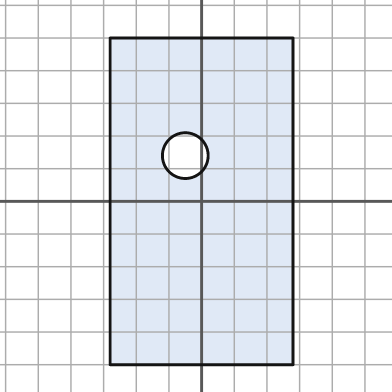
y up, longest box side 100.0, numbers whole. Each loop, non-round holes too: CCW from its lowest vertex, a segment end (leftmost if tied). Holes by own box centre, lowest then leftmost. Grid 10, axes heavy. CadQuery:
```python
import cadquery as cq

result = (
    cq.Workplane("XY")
    .moveTo(-28.0, -50.0)
    .lineTo(28.0, -50.0)
    .lineTo(28.0, 50.0)
    .lineTo(-28.0, 50.0)
    .close()
    .moveTo(-5.0, 14.0)
    .circle(7.0)
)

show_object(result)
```